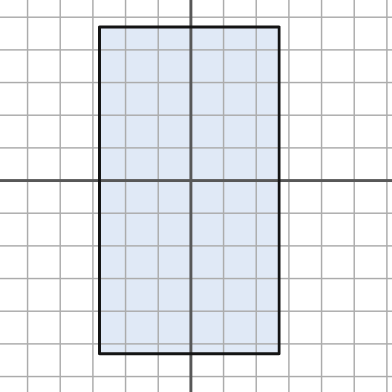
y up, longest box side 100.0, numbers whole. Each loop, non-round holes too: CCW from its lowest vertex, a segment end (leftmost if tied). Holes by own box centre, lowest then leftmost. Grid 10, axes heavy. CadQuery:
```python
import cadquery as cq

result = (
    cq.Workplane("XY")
    .moveTo(-28.0, -53.0)
    .lineTo(27.0, -53.0)
    .lineTo(27.0, 47.0)
    .lineTo(-28.0, 47.0)
    .close()
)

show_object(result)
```